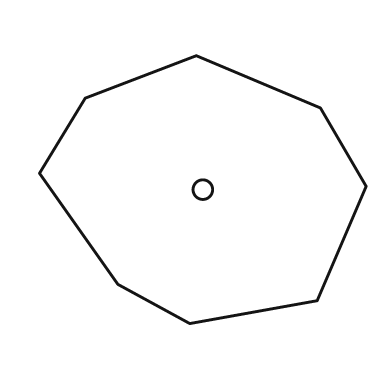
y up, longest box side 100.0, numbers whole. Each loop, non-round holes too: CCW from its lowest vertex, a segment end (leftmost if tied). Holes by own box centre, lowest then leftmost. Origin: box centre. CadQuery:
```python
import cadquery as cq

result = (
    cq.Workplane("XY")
    .moveTo(-4.0, -41.0)
    .lineTo(35.0, -34.0)
    .lineTo(50.0, 1.0)
    .lineTo(36.0, 25.0)
    .lineTo(-2.0, 41.0)
    .lineTo(-36.0, 28.0)
    .lineTo(-50.0, 5.0)
    .lineTo(-26.0, -29.0)
    .close()
    .moveTo(0.0, 0.0)
    .circle(3.0)
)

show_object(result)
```